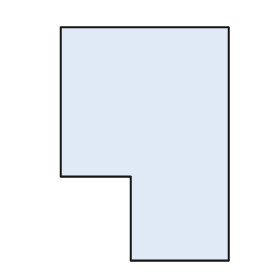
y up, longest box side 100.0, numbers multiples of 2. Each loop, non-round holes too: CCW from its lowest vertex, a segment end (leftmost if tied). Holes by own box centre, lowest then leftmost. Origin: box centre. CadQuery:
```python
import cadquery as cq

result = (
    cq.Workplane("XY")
    .moveTo(-6.0, -50.0)
    .lineTo(36.0, -50.0)
    .lineTo(36.0, 50.0)
    .lineTo(-36.0, 50.0)
    .lineTo(-36.0, -14.0)
    .lineTo(-6.0, -14.0)
    .close()
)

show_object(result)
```